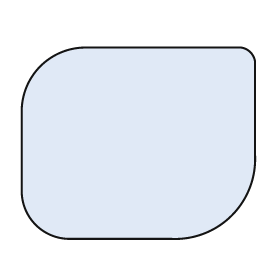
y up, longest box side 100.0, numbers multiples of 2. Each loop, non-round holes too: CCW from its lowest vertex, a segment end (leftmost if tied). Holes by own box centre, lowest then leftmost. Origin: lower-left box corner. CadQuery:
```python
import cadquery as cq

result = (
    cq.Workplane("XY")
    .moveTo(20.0, 0.0)
    .lineTo(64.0, 0.0)
    .threePointArc((90.0, 10.0), (100.0, 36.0))
    .lineTo(100.0, 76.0)
    .threePointArc((98.0, 80.0), (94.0, 82.0))
    .lineTo(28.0, 82.0)
    .threePointArc((8.0, 74.0), (0.0, 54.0))
    .lineTo(0.0, 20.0)
    .threePointArc((6.0, 6.0), (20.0, 0.0))
    .close()
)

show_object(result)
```